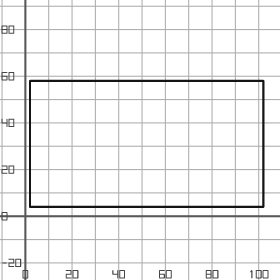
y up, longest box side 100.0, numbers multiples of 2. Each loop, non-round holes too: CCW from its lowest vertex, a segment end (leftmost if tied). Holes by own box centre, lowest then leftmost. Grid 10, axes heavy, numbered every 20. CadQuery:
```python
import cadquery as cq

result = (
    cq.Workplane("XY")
    .moveTo(2.0, 4.0)
    .lineTo(102.0, 4.0)
    .lineTo(102.0, 58.0)
    .lineTo(2.0, 58.0)
    .close()
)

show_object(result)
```